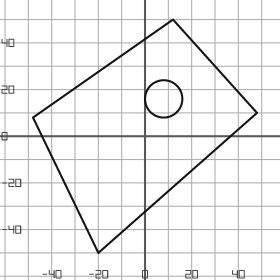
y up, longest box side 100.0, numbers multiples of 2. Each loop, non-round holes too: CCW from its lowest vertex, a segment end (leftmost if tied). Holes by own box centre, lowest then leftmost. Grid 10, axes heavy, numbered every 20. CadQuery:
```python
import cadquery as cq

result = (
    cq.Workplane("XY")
    .moveTo(-20.0, -50.0)
    .lineTo(48.0, 10.0)
    .lineTo(12.0, 50.0)
    .lineTo(-48.0, 8.0)
    .close()
    .moveTo(8.0, 16.0)
    .circle(8.0)
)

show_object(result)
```